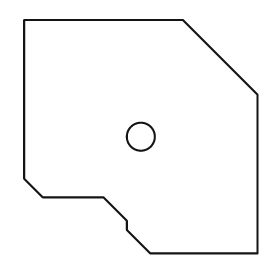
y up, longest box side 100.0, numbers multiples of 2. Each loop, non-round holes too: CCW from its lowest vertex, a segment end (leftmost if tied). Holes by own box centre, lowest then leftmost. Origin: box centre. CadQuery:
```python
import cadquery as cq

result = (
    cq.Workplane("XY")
    .moveTo(4.0, -50.0)
    .lineTo(50.0, -50.0)
    .lineTo(50.0, 18.0)
    .lineTo(18.0, 50.0)
    .lineTo(-50.0, 50.0)
    .lineTo(-50.0, -18.0)
    .lineTo(-42.0, -26.0)
    .lineTo(-16.0, -26.0)
    .lineTo(-6.0, -36.0)
    .lineTo(-6.0, -40.0)
    .close()
    .moveTo(0.0, 0.0)
    .circle(6.0)
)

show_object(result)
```